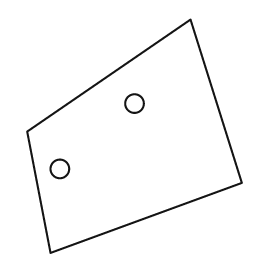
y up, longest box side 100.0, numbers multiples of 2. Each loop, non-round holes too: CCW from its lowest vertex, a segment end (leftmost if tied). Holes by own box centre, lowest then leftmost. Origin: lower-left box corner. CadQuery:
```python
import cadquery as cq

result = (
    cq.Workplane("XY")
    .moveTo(10.0, 0.0)
    .lineTo(92.0, 30.0)
    .lineTo(70.0, 100.0)
    .lineTo(0.0, 52.0)
    .close()
    .moveTo(14.0, 36.0)
    .circle(4.0)
    .moveTo(46.0, 64.0)
    .circle(4.0)
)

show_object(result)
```